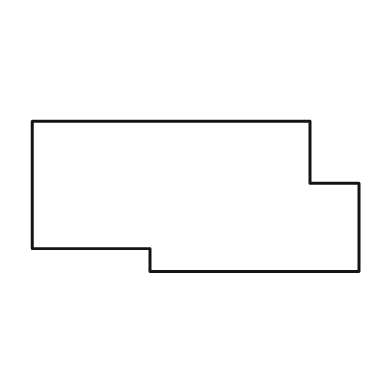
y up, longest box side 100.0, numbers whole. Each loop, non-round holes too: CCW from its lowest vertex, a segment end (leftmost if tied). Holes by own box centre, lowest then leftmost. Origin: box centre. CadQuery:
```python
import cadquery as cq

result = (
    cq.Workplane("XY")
    .moveTo(-14.0, -23.0)
    .lineTo(50.0, -23.0)
    .lineTo(50.0, 4.0)
    .lineTo(35.0, 4.0)
    .lineTo(35.0, 23.0)
    .lineTo(-50.0, 23.0)
    .lineTo(-50.0, -16.0)
    .lineTo(-14.0, -16.0)
    .close()
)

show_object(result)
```